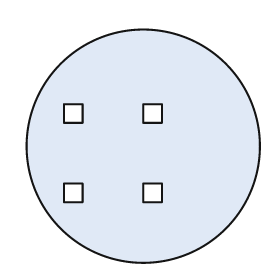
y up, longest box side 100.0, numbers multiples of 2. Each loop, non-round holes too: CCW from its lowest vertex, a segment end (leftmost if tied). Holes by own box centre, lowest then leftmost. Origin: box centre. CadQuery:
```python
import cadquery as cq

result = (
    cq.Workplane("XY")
    .moveTo(0.0, 0.0)
    .circle(50.0)
    .moveTo(-34.0, -24.0)
    .lineTo(-26.0, -24.0)
    .lineTo(-26.0, -16.0)
    .lineTo(-34.0, -16.0)
    .close()
    .moveTo(0.0, -24.0)
    .lineTo(8.0, -24.0)
    .lineTo(8.0, -16.0)
    .lineTo(0.0, -16.0)
    .close()
    .moveTo(-34.0, 10.0)
    .lineTo(-26.0, 10.0)
    .lineTo(-26.0, 18.0)
    .lineTo(-34.0, 18.0)
    .close()
    .moveTo(0.0, 10.0)
    .lineTo(8.0, 10.0)
    .lineTo(8.0, 18.0)
    .lineTo(0.0, 18.0)
    .close()
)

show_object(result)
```